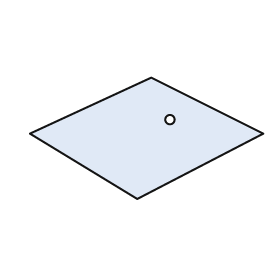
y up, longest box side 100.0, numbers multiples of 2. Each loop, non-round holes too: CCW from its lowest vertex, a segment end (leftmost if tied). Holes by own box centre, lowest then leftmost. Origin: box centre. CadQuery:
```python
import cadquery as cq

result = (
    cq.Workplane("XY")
    .moveTo(-4.0, -26.0)
    .lineTo(50.0, 2.0)
    .lineTo(2.0, 26.0)
    .lineTo(-50.0, 2.0)
    .close()
    .moveTo(10.0, 8.0)
    .circle(2.0)
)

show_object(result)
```